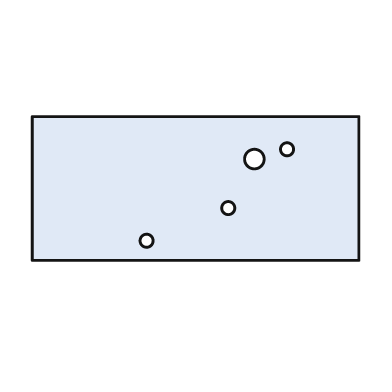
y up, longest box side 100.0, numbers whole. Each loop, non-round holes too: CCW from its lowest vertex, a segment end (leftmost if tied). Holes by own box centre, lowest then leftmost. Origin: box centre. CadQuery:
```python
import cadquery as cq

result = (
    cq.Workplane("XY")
    .moveTo(-50.0, -22.0)
    .lineTo(50.0, -22.0)
    .lineTo(50.0, 22.0)
    .lineTo(-50.0, 22.0)
    .close()
    .moveTo(-15.0, -16.0)
    .circle(2.0)
    .moveTo(10.0, -6.0)
    .circle(2.0)
    .moveTo(18.0, 9.0)
    .circle(3.0)
    .moveTo(28.0, 12.0)
    .circle(2.0)
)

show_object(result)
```